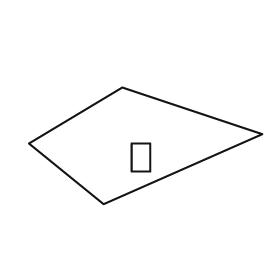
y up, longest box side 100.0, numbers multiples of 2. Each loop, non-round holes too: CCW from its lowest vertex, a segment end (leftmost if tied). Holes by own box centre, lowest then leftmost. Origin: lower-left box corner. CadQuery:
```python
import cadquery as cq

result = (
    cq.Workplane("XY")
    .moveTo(32.0, 0.0)
    .lineTo(100.0, 30.0)
    .lineTo(40.0, 50.0)
    .lineTo(0.0, 26.0)
    .close()
    .moveTo(44.0, 14.0)
    .lineTo(52.0, 14.0)
    .lineTo(52.0, 26.0)
    .lineTo(44.0, 26.0)
    .close()
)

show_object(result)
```